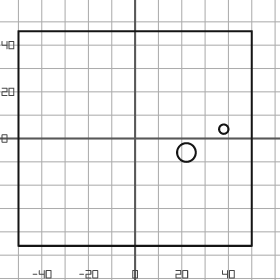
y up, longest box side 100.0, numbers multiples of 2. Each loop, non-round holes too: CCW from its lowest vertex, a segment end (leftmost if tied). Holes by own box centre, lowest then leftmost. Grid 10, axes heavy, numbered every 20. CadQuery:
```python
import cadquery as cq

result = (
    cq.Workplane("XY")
    .moveTo(-50.0, -46.0)
    .lineTo(50.0, -46.0)
    .lineTo(50.0, 46.0)
    .lineTo(-50.0, 46.0)
    .close()
    .moveTo(22.0, -6.0)
    .circle(4.0)
    .moveTo(38.0, 4.0)
    .circle(2.0)
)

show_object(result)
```